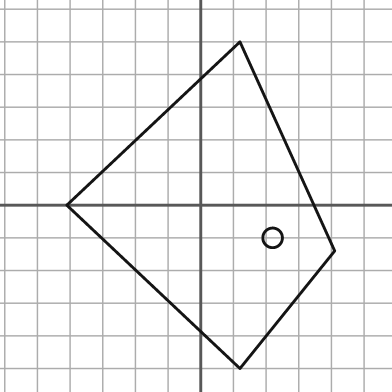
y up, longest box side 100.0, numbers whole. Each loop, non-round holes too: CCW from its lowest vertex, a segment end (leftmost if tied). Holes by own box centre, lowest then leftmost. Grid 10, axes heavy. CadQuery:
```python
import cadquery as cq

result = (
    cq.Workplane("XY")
    .moveTo(12.0, -50.0)
    .lineTo(41.0, -14.0)
    .lineTo(12.0, 50.0)
    .lineTo(-41.0, 0.0)
    .close()
    .moveTo(22.0, -10.0)
    .circle(3.0)
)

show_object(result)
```